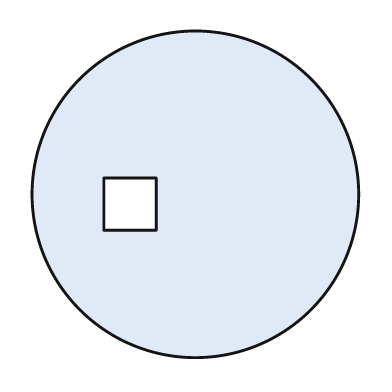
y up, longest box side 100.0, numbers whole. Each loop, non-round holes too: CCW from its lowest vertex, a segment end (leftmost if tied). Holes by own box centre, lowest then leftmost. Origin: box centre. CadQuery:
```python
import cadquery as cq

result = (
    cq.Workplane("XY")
    .moveTo(0.0, 0.0)
    .circle(50.0)
    .moveTo(-28.0, -11.0)
    .lineTo(-12.0, -11.0)
    .lineTo(-12.0, 5.0)
    .lineTo(-28.0, 5.0)
    .close()
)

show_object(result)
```